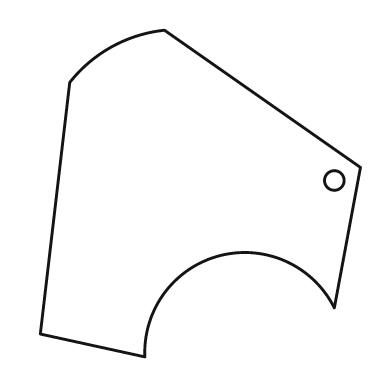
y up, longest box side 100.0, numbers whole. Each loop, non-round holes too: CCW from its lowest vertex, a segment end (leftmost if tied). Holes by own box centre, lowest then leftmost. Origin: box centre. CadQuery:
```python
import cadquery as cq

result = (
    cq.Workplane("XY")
    .moveTo(-17.0, -50.0)
    .threePointArc((6.0, -19.0), (41.0, -35.0))
    .lineTo(49.0, 8.0)
    .lineTo(-11.0, 50.0)
    .threePointArc((-27.0, 45.0), (-40.0, 34.0))
    .lineTo(-49.0, -43.0)
    .close()
    .moveTo(41.0, 4.0)
    .circle(3.0)
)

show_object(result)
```